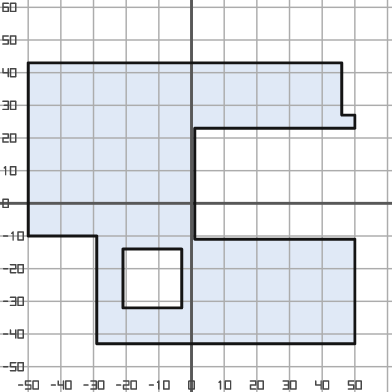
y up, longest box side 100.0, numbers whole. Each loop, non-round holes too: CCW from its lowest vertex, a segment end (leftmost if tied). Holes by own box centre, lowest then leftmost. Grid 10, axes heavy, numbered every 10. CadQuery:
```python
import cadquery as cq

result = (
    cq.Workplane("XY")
    .moveTo(-29.0, -43.0)
    .lineTo(50.0, -43.0)
    .lineTo(50.0, -11.0)
    .lineTo(1.0, -11.0)
    .lineTo(1.0, 23.0)
    .lineTo(50.0, 23.0)
    .lineTo(50.0, 27.0)
    .lineTo(46.0, 27.0)
    .lineTo(46.0, 43.0)
    .lineTo(-50.0, 43.0)
    .lineTo(-50.0, -10.0)
    .lineTo(-29.0, -10.0)
    .close()
    .moveTo(-21.0, -32.0)
    .lineTo(-3.0, -32.0)
    .lineTo(-3.0, -14.0)
    .lineTo(-21.0, -14.0)
    .close()
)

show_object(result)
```